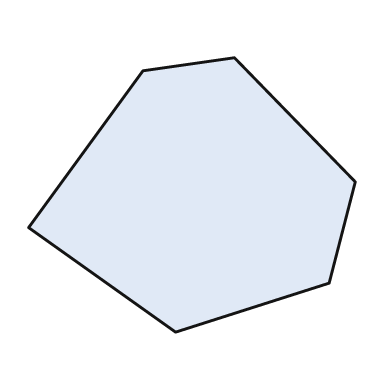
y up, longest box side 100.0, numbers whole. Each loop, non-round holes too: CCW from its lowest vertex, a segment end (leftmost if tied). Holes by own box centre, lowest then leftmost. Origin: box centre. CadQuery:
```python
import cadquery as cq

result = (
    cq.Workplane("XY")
    .moveTo(-5.0, -42.0)
    .lineTo(42.0, -27.0)
    .lineTo(50.0, 4.0)
    .lineTo(13.0, 42.0)
    .lineTo(-15.0, 38.0)
    .lineTo(-50.0, -10.0)
    .close()
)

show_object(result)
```